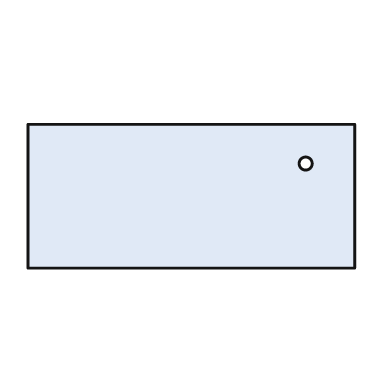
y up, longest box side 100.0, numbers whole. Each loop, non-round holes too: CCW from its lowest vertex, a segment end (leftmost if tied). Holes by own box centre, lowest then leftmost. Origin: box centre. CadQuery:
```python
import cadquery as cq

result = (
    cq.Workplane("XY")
    .moveTo(-50.0, -22.0)
    .lineTo(50.0, -22.0)
    .lineTo(50.0, 22.0)
    .lineTo(-50.0, 22.0)
    .close()
    .moveTo(35.0, 10.0)
    .circle(2.0)
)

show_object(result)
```